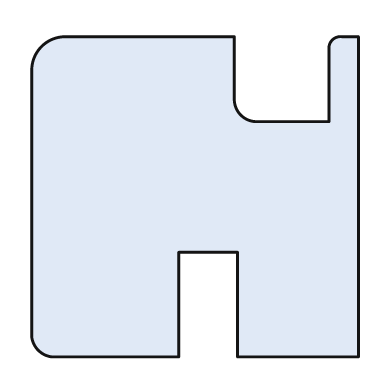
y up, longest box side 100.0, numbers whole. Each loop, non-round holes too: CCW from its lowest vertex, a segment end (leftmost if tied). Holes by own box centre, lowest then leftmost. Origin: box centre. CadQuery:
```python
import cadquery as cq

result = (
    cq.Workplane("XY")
    .moveTo(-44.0, -49.0)
    .lineTo(-5.0, -49.0)
    .lineTo(-5.0, -17.0)
    .lineTo(13.0, -17.0)
    .lineTo(13.0, -49.0)
    .lineTo(50.0, -49.0)
    .lineTo(50.0, 49.0)
    .lineTo(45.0, 49.0)
    .threePointArc((42.0, 48.0), (41.0, 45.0))
    .lineTo(41.0, 23.0)
    .lineTo(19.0, 23.0)
    .threePointArc((14.0, 25.0), (12.0, 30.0))
    .lineTo(12.0, 49.0)
    .lineTo(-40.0, 49.0)
    .threePointArc((-47.0, 46.0), (-50.0, 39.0))
    .lineTo(-50.0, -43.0)
    .threePointArc((-48.0, -47.0), (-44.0, -49.0))
    .close()
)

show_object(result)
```